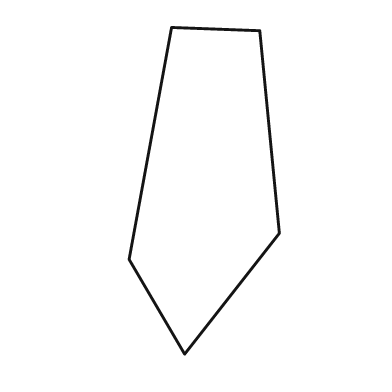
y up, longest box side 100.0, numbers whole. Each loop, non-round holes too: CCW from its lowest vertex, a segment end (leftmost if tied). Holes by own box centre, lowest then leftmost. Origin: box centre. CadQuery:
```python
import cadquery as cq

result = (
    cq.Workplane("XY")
    .moveTo(-6.0, -50.0)
    .lineTo(23.0, -13.0)
    .lineTo(17.0, 49.0)
    .lineTo(-10.0, 50.0)
    .lineTo(-23.0, -21.0)
    .close()
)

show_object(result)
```